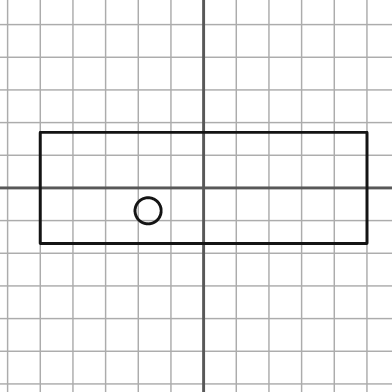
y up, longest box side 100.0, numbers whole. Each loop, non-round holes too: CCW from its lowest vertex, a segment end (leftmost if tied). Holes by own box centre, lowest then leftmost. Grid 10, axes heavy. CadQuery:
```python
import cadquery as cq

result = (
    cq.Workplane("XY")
    .moveTo(-50.0, -17.0)
    .lineTo(50.0, -17.0)
    .lineTo(50.0, 17.0)
    .lineTo(-50.0, 17.0)
    .close()
    .moveTo(-17.0, -7.0)
    .circle(4.0)
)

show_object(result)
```